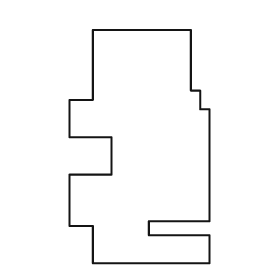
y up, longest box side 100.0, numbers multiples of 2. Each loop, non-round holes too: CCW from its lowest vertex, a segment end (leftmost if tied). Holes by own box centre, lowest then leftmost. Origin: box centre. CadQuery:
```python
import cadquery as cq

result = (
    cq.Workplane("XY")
    .moveTo(-20.0, -50.0)
    .lineTo(30.0, -50.0)
    .lineTo(30.0, -38.0)
    .lineTo(4.0, -38.0)
    .lineTo(4.0, -32.0)
    .lineTo(30.0, -32.0)
    .lineTo(30.0, 16.0)
    .lineTo(26.0, 16.0)
    .lineTo(26.0, 24.0)
    .lineTo(22.0, 24.0)
    .lineTo(22.0, 50.0)
    .lineTo(-20.0, 50.0)
    .lineTo(-20.0, 20.0)
    .lineTo(-30.0, 20.0)
    .lineTo(-30.0, 4.0)
    .lineTo(-12.0, 4.0)
    .lineTo(-12.0, -12.0)
    .lineTo(-30.0, -12.0)
    .lineTo(-30.0, -34.0)
    .lineTo(-20.0, -34.0)
    .close()
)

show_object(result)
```